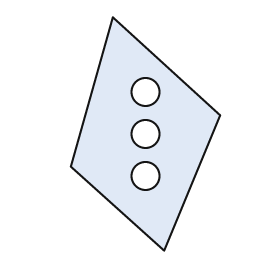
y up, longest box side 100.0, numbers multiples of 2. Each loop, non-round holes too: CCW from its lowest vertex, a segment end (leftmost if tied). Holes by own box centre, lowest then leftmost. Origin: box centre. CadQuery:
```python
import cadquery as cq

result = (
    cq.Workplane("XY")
    .moveTo(8.0, -50.0)
    .lineTo(32.0, 8.0)
    .lineTo(-14.0, 50.0)
    .lineTo(-32.0, -14.0)
    .close()
    .moveTo(0.0, -18.0)
    .circle(6.0)
    .moveTo(0.0, 0.0)
    .circle(6.0)
    .moveTo(0.0, 18.0)
    .circle(6.0)
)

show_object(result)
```